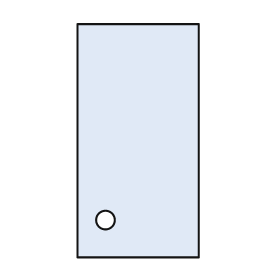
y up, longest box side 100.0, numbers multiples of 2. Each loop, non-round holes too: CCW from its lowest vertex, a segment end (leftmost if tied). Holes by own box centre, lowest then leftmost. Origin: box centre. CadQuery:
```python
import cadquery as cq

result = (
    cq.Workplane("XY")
    .moveTo(-26.0, -50.0)
    .lineTo(26.0, -50.0)
    .lineTo(26.0, 50.0)
    .lineTo(-26.0, 50.0)
    .close()
    .moveTo(-14.0, -34.0)
    .circle(4.0)
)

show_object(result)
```